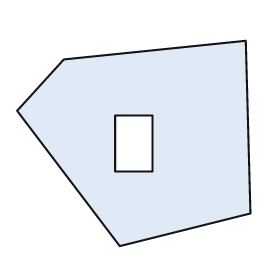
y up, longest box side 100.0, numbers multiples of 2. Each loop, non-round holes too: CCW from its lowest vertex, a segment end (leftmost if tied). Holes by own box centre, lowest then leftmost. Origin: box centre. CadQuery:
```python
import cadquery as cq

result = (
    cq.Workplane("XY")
    .moveTo(-6.0, -44.0)
    .lineTo(50.0, -30.0)
    .lineTo(48.0, 44.0)
    .lineTo(-30.0, 36.0)
    .lineTo(-50.0, 14.0)
    .close()
    .moveTo(-8.0, -12.0)
    .lineTo(8.0, -12.0)
    .lineTo(8.0, 12.0)
    .lineTo(-8.0, 12.0)
    .close()
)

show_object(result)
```